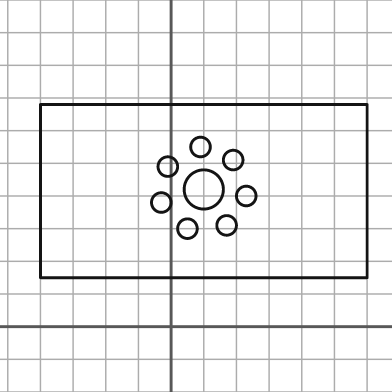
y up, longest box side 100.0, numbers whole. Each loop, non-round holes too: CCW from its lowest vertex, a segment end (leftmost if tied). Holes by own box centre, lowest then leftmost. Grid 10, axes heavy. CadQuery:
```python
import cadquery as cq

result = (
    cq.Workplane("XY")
    .moveTo(-40.0, 15.0)
    .lineTo(60.0, 15.0)
    .lineTo(60.0, 68.0)
    .lineTo(-40.0, 68.0)
    .close()
    .moveTo(5.0, 30.0)
    .circle(3.0)
    .moveTo(17.0, 31.0)
    .circle(3.0)
    .moveTo(-3.0, 38.0)
    .circle(3.0)
    .moveTo(23.0, 40.0)
    .circle(3.0)
    .moveTo(10.0, 42.0)
    .circle(6.0)
    .moveTo(-1.0, 49.0)
    .circle(3.0)
    .moveTo(19.0, 51.0)
    .circle(3.0)
    .moveTo(9.0, 55.0)
    .circle(3.0)
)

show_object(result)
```